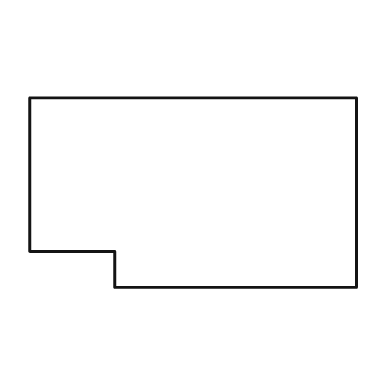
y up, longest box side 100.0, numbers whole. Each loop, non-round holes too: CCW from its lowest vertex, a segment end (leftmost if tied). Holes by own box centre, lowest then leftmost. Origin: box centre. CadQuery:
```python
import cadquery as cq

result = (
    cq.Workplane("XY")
    .moveTo(-24.0, -29.0)
    .lineTo(50.0, -29.0)
    .lineTo(50.0, 29.0)
    .lineTo(-50.0, 29.0)
    .lineTo(-50.0, -18.0)
    .lineTo(-24.0, -18.0)
    .close()
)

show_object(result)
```